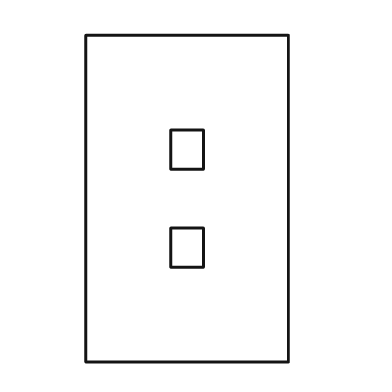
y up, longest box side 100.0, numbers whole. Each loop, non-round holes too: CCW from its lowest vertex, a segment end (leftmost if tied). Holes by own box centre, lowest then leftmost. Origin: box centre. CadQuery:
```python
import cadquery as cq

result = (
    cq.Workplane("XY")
    .moveTo(-31.0, -50.0)
    .lineTo(31.0, -50.0)
    .lineTo(31.0, 50.0)
    .lineTo(-31.0, 50.0)
    .close()
    .moveTo(-5.0, -21.0)
    .lineTo(5.0, -21.0)
    .lineTo(5.0, -9.0)
    .lineTo(-5.0, -9.0)
    .close()
    .moveTo(-5.0, 9.0)
    .lineTo(5.0, 9.0)
    .lineTo(5.0, 21.0)
    .lineTo(-5.0, 21.0)
    .close()
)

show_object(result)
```